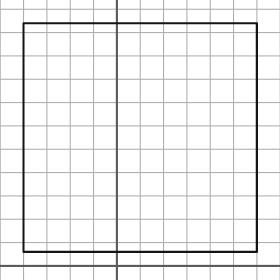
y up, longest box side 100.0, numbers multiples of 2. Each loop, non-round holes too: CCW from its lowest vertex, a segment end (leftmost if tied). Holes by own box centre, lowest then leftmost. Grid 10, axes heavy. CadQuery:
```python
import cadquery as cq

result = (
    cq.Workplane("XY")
    .moveTo(-40.0, 6.0)
    .lineTo(60.0, 6.0)
    .lineTo(60.0, 104.0)
    .lineTo(-40.0, 104.0)
    .close()
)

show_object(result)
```